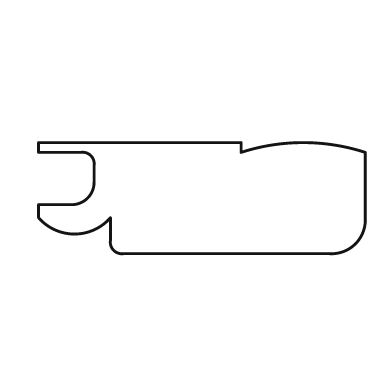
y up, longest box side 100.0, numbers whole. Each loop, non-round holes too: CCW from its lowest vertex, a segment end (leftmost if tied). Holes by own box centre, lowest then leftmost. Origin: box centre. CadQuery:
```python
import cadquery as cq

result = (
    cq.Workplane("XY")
    .moveTo(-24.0, -17.0)
    .lineTo(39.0, -17.0)
    .threePointArc((47.0, -14.0), (50.0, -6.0))
    .lineTo(50.0, 14.0)
    .threePointArc((31.0, 17.0), (12.0, 14.0))
    .lineTo(12.0, 17.0)
    .lineTo(-50.0, 17.0)
    .lineTo(-50.0, 14.0)
    .lineTo(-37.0, 14.0)
    .threePointArc((-34.0, 13.0), (-33.0, 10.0))
    .lineTo(-33.0, 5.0)
    .threePointArc((-35.0, 0.0), (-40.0, -2.0))
    .lineTo(-50.0, -2.0)
    .lineTo(-50.0, -6.0)
    .threePointArc((-39.0, -11.0), (-28.0, -6.0))
    .lineTo(-28.0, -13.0)
    .threePointArc((-27.0, -16.0), (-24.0, -17.0))
    .close()
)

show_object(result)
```